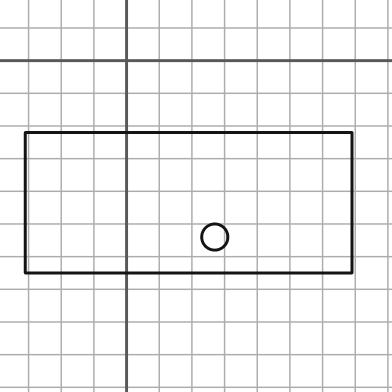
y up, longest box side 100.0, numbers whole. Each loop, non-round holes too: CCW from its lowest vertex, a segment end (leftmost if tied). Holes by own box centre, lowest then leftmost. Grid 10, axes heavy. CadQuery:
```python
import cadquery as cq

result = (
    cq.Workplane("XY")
    .moveTo(-31.0, -65.0)
    .lineTo(69.0, -65.0)
    .lineTo(69.0, -22.0)
    .lineTo(-31.0, -22.0)
    .close()
    .moveTo(27.0, -54.0)
    .circle(4.0)
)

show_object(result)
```